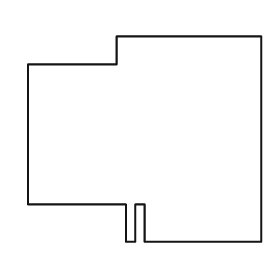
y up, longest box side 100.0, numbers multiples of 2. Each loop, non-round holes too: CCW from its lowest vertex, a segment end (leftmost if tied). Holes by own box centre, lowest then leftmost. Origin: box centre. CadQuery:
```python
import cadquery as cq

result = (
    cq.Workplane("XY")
    .moveTo(-8.0, -44.0)
    .lineTo(-4.0, -44.0)
    .lineTo(-4.0, -28.0)
    .lineTo(0.0, -28.0)
    .lineTo(0.0, -44.0)
    .lineTo(50.0, -44.0)
    .lineTo(50.0, 44.0)
    .lineTo(-12.0, 44.0)
    .lineTo(-12.0, 32.0)
    .lineTo(-50.0, 32.0)
    .lineTo(-50.0, -28.0)
    .lineTo(-8.0, -28.0)
    .close()
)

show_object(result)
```